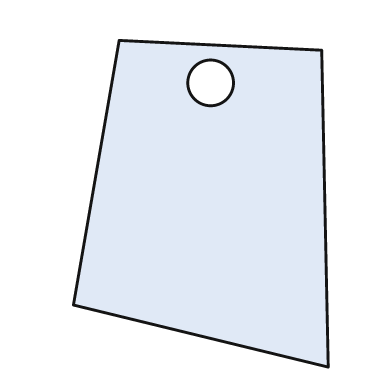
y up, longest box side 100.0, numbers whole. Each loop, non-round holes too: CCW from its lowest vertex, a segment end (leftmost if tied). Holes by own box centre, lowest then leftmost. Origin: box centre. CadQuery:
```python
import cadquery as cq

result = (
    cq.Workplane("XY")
    .moveTo(39.0, -50.0)
    .lineTo(37.0, 47.0)
    .lineTo(-25.0, 50.0)
    .lineTo(-39.0, -31.0)
    .close()
    .moveTo(3.0, 37.0)
    .circle(7.0)
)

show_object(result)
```